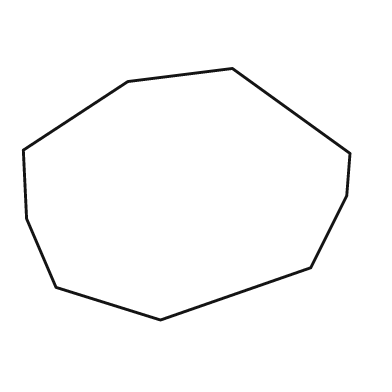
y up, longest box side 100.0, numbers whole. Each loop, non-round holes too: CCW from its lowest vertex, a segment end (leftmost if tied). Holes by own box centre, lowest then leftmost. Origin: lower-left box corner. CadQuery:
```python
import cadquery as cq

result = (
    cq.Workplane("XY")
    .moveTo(42.0, 0.0)
    .lineTo(88.0, 16.0)
    .lineTo(99.0, 38.0)
    .lineTo(100.0, 51.0)
    .lineTo(64.0, 77.0)
    .lineTo(32.0, 73.0)
    .lineTo(0.0, 52.0)
    .lineTo(1.0, 31.0)
    .lineTo(10.0, 10.0)
    .close()
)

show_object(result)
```